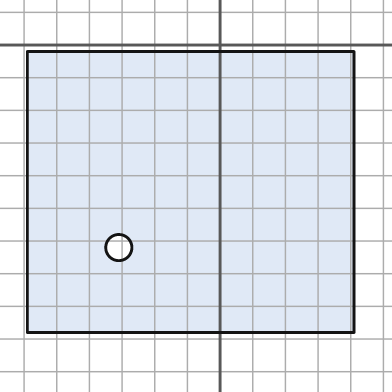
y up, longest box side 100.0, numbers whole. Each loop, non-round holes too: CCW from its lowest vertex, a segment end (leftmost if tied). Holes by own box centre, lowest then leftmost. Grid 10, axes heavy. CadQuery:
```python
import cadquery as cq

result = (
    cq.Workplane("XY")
    .moveTo(-59.0, -88.0)
    .lineTo(41.0, -88.0)
    .lineTo(41.0, -2.0)
    .lineTo(-59.0, -2.0)
    .close()
    .moveTo(-31.0, -62.0)
    .circle(4.0)
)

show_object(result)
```